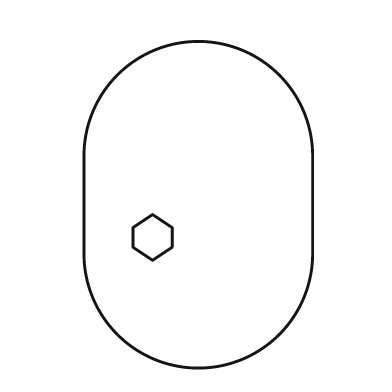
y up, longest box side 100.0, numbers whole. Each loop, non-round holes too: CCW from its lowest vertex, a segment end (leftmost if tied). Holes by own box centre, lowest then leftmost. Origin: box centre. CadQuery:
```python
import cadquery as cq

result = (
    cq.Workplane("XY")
    .moveTo(-35.0, -15.0)
    .threePointArc((0.0, -50.0), (35.0, -15.0))
    .lineTo(35.0, 15.0)
    .threePointArc((0.0, 50.0), (-35.0, 15.0))
    .close()
    .moveTo(-14.0, -17.0)
    .lineTo(-8.0, -13.0)
    .lineTo(-8.0, -7.0)
    .lineTo(-14.0, -3.0)
    .lineTo(-20.0, -7.0)
    .lineTo(-20.0, -13.0)
    .close()
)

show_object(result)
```